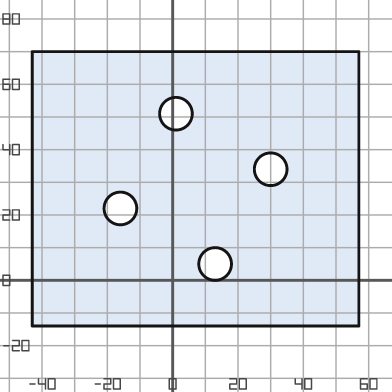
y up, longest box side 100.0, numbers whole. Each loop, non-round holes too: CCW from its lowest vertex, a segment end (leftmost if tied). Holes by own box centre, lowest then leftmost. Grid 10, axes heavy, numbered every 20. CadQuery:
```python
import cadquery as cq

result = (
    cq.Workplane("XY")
    .moveTo(-43.0, -14.0)
    .lineTo(57.0, -14.0)
    .lineTo(57.0, 70.0)
    .lineTo(-43.0, 70.0)
    .close()
    .moveTo(13.0, 5.0)
    .circle(5.0)
    .moveTo(-16.0, 22.0)
    .circle(5.0)
    .moveTo(30.0, 34.0)
    .circle(5.0)
    .moveTo(1.0, 51.0)
    .circle(5.0)
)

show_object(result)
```